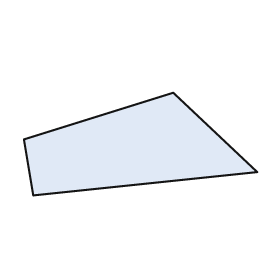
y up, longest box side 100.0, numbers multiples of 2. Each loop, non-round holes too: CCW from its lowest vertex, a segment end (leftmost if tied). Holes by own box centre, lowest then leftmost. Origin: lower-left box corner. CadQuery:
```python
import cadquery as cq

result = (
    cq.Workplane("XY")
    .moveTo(4.0, 0.0)
    .lineTo(100.0, 10.0)
    .lineTo(64.0, 44.0)
    .lineTo(0.0, 24.0)
    .close()
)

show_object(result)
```